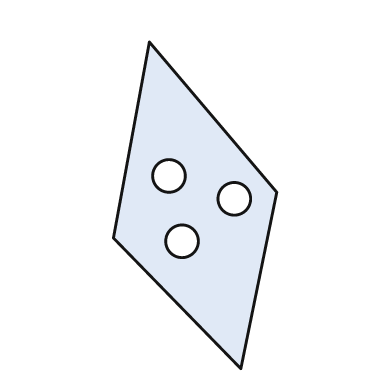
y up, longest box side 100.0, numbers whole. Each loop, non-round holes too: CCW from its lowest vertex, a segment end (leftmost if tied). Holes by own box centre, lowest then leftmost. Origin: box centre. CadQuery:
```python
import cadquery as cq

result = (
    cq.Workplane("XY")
    .moveTo(14.0, -50.0)
    .lineTo(25.0, 4.0)
    .lineTo(-14.0, 50.0)
    .lineTo(-25.0, -10.0)
    .close()
    .moveTo(-4.0, -11.0)
    .circle(5.0)
    .moveTo(12.0, 2.0)
    .circle(5.0)
    .moveTo(-8.0, 9.0)
    .circle(5.0)
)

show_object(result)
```